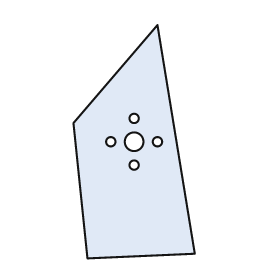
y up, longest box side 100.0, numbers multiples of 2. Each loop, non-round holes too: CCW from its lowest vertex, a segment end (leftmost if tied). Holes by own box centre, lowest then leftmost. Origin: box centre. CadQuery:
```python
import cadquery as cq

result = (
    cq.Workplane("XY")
    .moveTo(-20.0, -50.0)
    .lineTo(26.0, -48.0)
    .lineTo(10.0, 50.0)
    .lineTo(-26.0, 8.0)
    .close()
    .moveTo(0.0, -10.0)
    .circle(2.0)
    .moveTo(-10.0, 0.0)
    .circle(2.0)
    .moveTo(0.0, 0.0)
    .circle(4.0)
    .moveTo(10.0, 0.0)
    .circle(2.0)
    .moveTo(0.0, 10.0)
    .circle(2.0)
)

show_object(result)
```